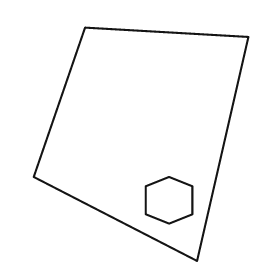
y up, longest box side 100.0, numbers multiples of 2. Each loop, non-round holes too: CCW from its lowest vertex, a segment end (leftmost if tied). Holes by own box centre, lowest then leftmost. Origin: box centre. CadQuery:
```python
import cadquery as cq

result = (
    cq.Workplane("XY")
    .moveTo(24.0, -50.0)
    .lineTo(46.0, 46.0)
    .lineTo(-24.0, 50.0)
    .lineTo(-46.0, -14.0)
    .close()
    .moveTo(12.0, -34.0)
    .lineTo(22.0, -30.0)
    .lineTo(22.0, -18.0)
    .lineTo(12.0, -14.0)
    .lineTo(2.0, -18.0)
    .lineTo(2.0, -30.0)
    .close()
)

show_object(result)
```